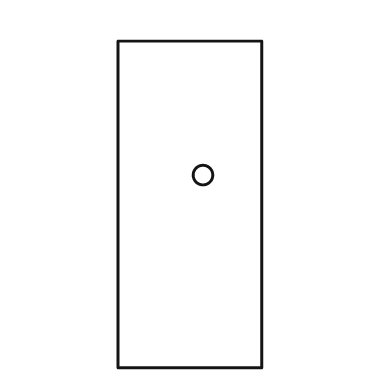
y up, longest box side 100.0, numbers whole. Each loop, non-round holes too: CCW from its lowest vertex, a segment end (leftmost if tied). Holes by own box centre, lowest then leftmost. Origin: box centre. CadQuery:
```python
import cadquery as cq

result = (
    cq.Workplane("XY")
    .moveTo(-22.0, -50.0)
    .lineTo(22.0, -50.0)
    .lineTo(22.0, 50.0)
    .lineTo(-22.0, 50.0)
    .close()
    .moveTo(4.0, 9.0)
    .circle(3.0)
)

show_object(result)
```